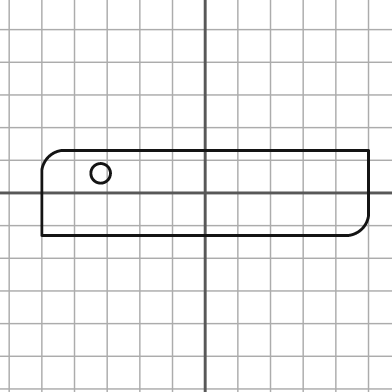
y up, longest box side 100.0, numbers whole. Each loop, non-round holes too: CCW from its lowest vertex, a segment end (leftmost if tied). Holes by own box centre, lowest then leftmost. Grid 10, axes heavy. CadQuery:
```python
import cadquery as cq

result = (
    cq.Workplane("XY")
    .moveTo(-50.0, -13.0)
    .lineTo(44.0, -13.0)
    .threePointArc((48.0, -11.0), (50.0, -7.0))
    .lineTo(50.0, 13.0)
    .lineTo(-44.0, 13.0)
    .threePointArc((-48.0, 11.0), (-50.0, 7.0))
    .close()
    .moveTo(-32.0, 6.0)
    .circle(3.0)
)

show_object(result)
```